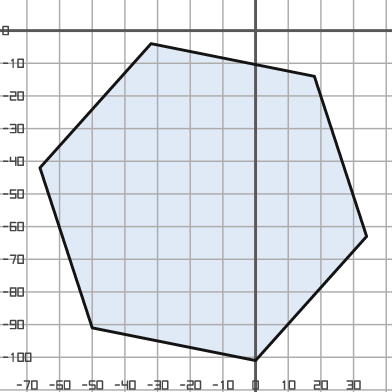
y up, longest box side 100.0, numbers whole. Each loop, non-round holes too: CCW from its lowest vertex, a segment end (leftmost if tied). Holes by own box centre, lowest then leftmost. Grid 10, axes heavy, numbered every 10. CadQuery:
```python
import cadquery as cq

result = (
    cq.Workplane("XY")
    .moveTo(0.0, -101.0)
    .lineTo(34.0, -63.0)
    .lineTo(18.0, -14.0)
    .lineTo(-32.0, -4.0)
    .lineTo(-66.0, -42.0)
    .lineTo(-50.0, -91.0)
    .close()
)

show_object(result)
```